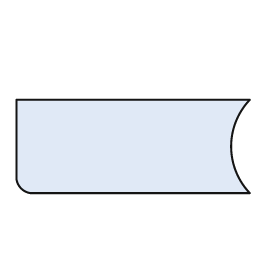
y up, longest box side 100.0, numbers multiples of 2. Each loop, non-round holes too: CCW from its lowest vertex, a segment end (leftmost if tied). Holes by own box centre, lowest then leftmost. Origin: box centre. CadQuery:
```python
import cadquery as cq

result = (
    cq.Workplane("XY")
    .moveTo(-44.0, -20.0)
    .lineTo(50.0, -20.0)
    .threePointArc((42.0, 0.0), (50.0, 20.0))
    .lineTo(-50.0, 20.0)
    .lineTo(-50.0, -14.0)
    .threePointArc((-48.0, -18.0), (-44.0, -20.0))
    .close()
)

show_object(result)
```